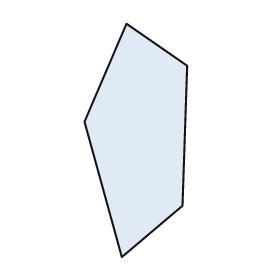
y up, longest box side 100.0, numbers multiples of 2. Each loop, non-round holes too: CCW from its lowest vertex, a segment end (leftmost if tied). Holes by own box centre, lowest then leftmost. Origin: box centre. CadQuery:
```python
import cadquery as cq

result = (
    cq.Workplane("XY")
    .moveTo(-6.0, -50.0)
    .lineTo(20.0, -28.0)
    .lineTo(22.0, 32.0)
    .lineTo(-4.0, 50.0)
    .lineTo(-22.0, 8.0)
    .close()
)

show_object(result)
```